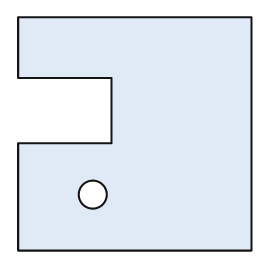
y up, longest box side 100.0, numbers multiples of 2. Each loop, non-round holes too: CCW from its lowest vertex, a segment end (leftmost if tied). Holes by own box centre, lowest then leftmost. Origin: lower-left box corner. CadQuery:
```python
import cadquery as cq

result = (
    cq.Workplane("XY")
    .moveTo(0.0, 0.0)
    .lineTo(100.0, 0.0)
    .lineTo(100.0, 100.0)
    .lineTo(0.0, 100.0)
    .lineTo(0.0, 74.0)
    .lineTo(40.0, 74.0)
    .lineTo(40.0, 46.0)
    .lineTo(0.0, 46.0)
    .close()
    .moveTo(32.0, 24.0)
    .circle(6.0)
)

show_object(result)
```